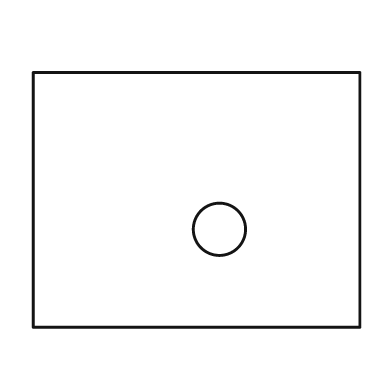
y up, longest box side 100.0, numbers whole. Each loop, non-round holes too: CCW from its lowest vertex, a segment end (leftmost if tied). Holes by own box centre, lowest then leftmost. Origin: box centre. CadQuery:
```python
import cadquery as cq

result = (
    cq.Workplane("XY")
    .moveTo(-50.0, -39.0)
    .lineTo(50.0, -39.0)
    .lineTo(50.0, 39.0)
    .lineTo(-50.0, 39.0)
    .close()
    .moveTo(7.0, -9.0)
    .circle(8.0)
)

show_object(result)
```